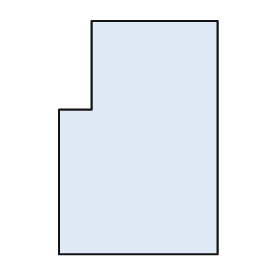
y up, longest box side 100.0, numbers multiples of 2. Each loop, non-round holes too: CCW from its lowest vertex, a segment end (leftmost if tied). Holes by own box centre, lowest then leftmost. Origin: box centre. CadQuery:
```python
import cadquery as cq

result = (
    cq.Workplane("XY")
    .moveTo(-34.0, -50.0)
    .lineTo(34.0, -50.0)
    .lineTo(34.0, 50.0)
    .lineTo(-20.0, 50.0)
    .lineTo(-20.0, 12.0)
    .lineTo(-34.0, 12.0)
    .close()
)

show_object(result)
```